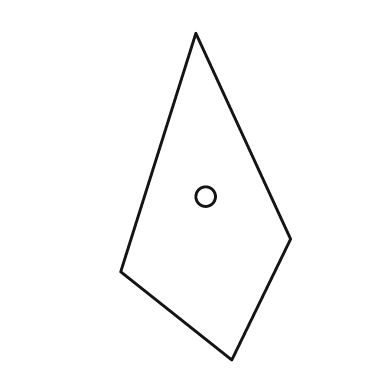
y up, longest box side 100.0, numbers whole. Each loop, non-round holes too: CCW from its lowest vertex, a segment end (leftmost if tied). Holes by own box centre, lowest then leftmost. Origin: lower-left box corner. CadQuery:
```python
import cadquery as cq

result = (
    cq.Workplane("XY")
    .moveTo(34.0, 0.0)
    .lineTo(52.0, 37.0)
    .lineTo(23.0, 100.0)
    .lineTo(0.0, 27.0)
    .close()
    .moveTo(26.0, 50.0)
    .circle(3.0)
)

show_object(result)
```